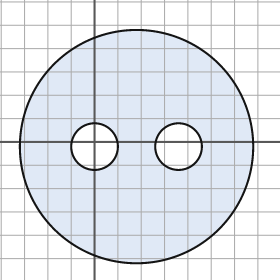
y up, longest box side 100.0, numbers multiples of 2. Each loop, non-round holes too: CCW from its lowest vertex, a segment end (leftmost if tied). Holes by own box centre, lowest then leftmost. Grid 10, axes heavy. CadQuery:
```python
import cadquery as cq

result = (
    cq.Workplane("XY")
    .moveTo(18.0, -2.0)
    .circle(50.0)
    .moveTo(0.0, -2.0)
    .circle(10.0)
    .moveTo(36.0, -2.0)
    .circle(10.0)
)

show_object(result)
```